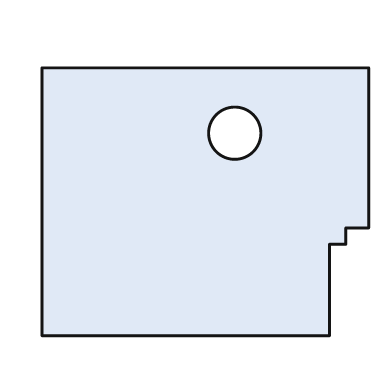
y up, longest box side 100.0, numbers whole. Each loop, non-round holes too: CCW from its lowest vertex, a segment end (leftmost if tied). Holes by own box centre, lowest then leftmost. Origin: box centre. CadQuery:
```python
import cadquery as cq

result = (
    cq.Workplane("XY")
    .moveTo(-50.0, -41.0)
    .lineTo(38.0, -41.0)
    .lineTo(38.0, -13.0)
    .lineTo(43.0, -13.0)
    .lineTo(43.0, -8.0)
    .lineTo(50.0, -8.0)
    .lineTo(50.0, 41.0)
    .lineTo(-50.0, 41.0)
    .close()
    .moveTo(9.0, 21.0)
    .circle(8.0)
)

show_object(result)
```